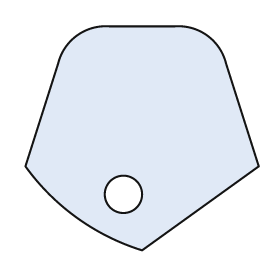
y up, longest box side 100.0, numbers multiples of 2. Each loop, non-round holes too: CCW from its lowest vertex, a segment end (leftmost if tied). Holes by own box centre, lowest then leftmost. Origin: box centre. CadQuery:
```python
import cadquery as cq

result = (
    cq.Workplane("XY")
    .moveTo(0.0, -48.0)
    .lineTo(50.0, -12.0)
    .lineTo(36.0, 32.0)
    .threePointArc((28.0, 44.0), (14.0, 48.0))
    .lineTo(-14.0, 48.0)
    .threePointArc((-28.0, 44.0), (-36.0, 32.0))
    .lineTo(-50.0, -12.0)
    .threePointArc((-28.0, -34.0), (0.0, -48.0))
    .close()
    .moveTo(-8.0, -24.0)
    .circle(8.0)
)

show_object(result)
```